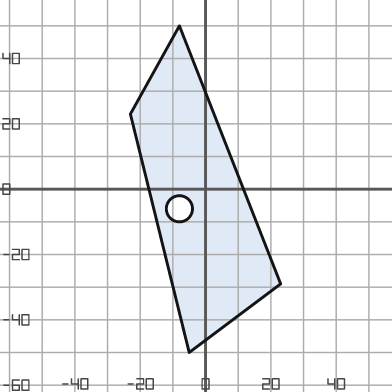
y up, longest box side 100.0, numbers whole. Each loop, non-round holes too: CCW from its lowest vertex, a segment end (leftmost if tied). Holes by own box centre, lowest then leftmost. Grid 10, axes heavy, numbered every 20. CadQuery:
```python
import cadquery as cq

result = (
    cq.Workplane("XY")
    .moveTo(-5.0, -50.0)
    .lineTo(23.0, -29.0)
    .lineTo(-8.0, 50.0)
    .lineTo(-23.0, 23.0)
    .close()
    .moveTo(-8.0, -6.0)
    .circle(4.0)
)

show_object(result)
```